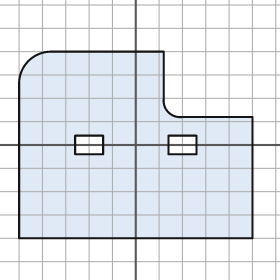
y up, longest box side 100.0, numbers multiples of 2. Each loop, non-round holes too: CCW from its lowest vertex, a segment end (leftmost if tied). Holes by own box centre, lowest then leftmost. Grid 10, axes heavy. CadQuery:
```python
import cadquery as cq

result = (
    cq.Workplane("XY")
    .moveTo(-50.0, -40.0)
    .lineTo(50.0, -40.0)
    .lineTo(50.0, 12.0)
    .lineTo(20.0, 12.0)
    .threePointArc((14.0, 14.0), (12.0, 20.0))
    .lineTo(12.0, 40.0)
    .lineTo(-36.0, 40.0)
    .threePointArc((-46.0, 36.0), (-50.0, 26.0))
    .close()
    .moveTo(-26.0, -4.0)
    .lineTo(-14.0, -4.0)
    .lineTo(-14.0, 4.0)
    .lineTo(-26.0, 4.0)
    .close()
    .moveTo(14.0, -4.0)
    .lineTo(26.0, -4.0)
    .lineTo(26.0, 4.0)
    .lineTo(14.0, 4.0)
    .close()
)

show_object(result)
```